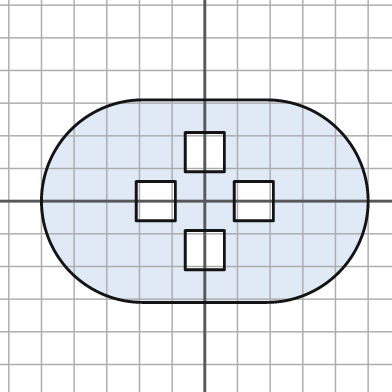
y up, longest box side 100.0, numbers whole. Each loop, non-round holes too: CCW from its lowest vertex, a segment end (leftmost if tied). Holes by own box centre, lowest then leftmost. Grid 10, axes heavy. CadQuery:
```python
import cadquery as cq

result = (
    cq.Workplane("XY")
    .moveTo(-19.0, -31.0)
    .lineTo(19.0, -31.0)
    .threePointArc((50.0, 0.0), (19.0, 31.0))
    .lineTo(-19.0, 31.0)
    .threePointArc((-50.0, 0.0), (-19.0, -31.0))
    .close()
    .moveTo(-6.0, -21.0)
    .lineTo(6.0, -21.0)
    .lineTo(6.0, -9.0)
    .lineTo(-6.0, -9.0)
    .close()
    .moveTo(-21.0, -6.0)
    .lineTo(-9.0, -6.0)
    .lineTo(-9.0, 6.0)
    .lineTo(-21.0, 6.0)
    .close()
    .moveTo(9.0, -6.0)
    .lineTo(21.0, -6.0)
    .lineTo(21.0, 6.0)
    .lineTo(9.0, 6.0)
    .close()
    .moveTo(-6.0, 9.0)
    .lineTo(6.0, 9.0)
    .lineTo(6.0, 21.0)
    .lineTo(-6.0, 21.0)
    .close()
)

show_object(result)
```